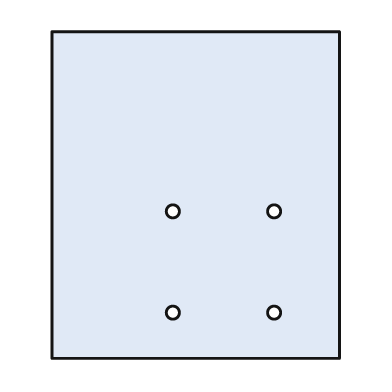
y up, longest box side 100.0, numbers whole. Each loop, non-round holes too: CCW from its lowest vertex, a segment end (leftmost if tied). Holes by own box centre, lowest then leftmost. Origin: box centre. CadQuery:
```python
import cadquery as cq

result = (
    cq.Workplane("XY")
    .moveTo(-44.0, -50.0)
    .lineTo(44.0, -50.0)
    .lineTo(44.0, 50.0)
    .lineTo(-44.0, 50.0)
    .close()
    .moveTo(-7.0, -36.0)
    .circle(2.0)
    .moveTo(24.0, -36.0)
    .circle(2.0)
    .moveTo(-7.0, -5.0)
    .circle(2.0)
    .moveTo(24.0, -5.0)
    .circle(2.0)
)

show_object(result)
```